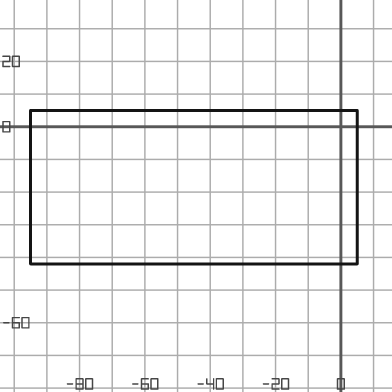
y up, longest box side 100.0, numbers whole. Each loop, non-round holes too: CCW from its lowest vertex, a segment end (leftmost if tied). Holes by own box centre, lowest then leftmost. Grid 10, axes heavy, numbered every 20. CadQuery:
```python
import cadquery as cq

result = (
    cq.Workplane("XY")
    .moveTo(-95.0, -42.0)
    .lineTo(5.0, -42.0)
    .lineTo(5.0, 5.0)
    .lineTo(-95.0, 5.0)
    .close()
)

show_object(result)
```